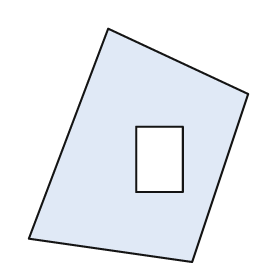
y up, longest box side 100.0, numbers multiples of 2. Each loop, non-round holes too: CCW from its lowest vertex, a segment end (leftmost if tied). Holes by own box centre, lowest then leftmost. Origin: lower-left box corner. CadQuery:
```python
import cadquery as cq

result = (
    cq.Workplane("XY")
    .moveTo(70.0, 0.0)
    .lineTo(94.0, 72.0)
    .lineTo(34.0, 100.0)
    .lineTo(0.0, 10.0)
    .close()
    .moveTo(46.0, 30.0)
    .lineTo(66.0, 30.0)
    .lineTo(66.0, 58.0)
    .lineTo(46.0, 58.0)
    .close()
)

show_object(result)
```